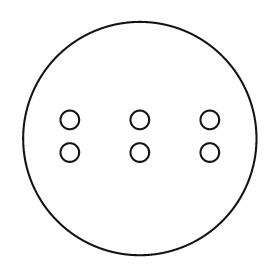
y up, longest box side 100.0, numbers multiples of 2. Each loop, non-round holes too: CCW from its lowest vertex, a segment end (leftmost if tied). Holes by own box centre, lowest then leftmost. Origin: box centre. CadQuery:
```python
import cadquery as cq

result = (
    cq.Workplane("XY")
    .moveTo(0.0, 0.0)
    .circle(50.0)
    .moveTo(-30.0, -6.0)
    .circle(4.0)
    .moveTo(0.0, -6.0)
    .circle(4.0)
    .moveTo(30.0, -6.0)
    .circle(4.0)
    .moveTo(-30.0, 8.0)
    .circle(4.0)
    .moveTo(0.0, 8.0)
    .circle(4.0)
    .moveTo(30.0, 8.0)
    .circle(4.0)
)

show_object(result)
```